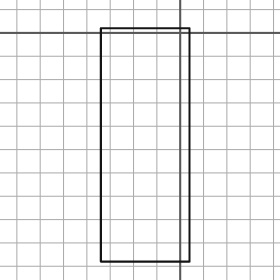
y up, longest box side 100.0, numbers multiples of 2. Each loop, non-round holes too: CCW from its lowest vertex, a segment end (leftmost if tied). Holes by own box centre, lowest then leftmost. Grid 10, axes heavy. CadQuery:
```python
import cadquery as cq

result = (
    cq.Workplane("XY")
    .moveTo(-34.0, -98.0)
    .lineTo(4.0, -98.0)
    .lineTo(4.0, 2.0)
    .lineTo(-34.0, 2.0)
    .close()
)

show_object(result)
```